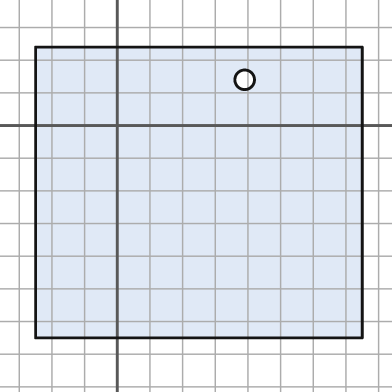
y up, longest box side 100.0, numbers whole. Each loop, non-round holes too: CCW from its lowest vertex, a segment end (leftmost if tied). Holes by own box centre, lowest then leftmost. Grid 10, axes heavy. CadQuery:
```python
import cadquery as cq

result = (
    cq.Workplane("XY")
    .moveTo(-25.0, -65.0)
    .lineTo(75.0, -65.0)
    .lineTo(75.0, 24.0)
    .lineTo(-25.0, 24.0)
    .close()
    .moveTo(39.0, 14.0)
    .circle(3.0)
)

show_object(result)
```